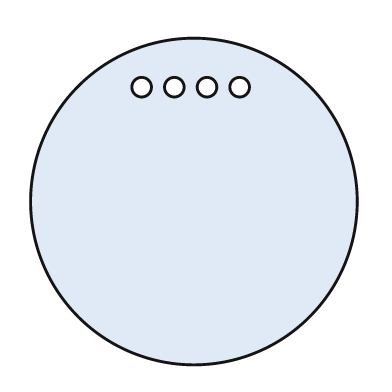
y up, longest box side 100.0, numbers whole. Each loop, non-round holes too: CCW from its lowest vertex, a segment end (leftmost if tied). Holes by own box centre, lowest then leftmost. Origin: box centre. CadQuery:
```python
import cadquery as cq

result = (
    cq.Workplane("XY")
    .moveTo(0.0, 0.0)
    .circle(50.0)
    .moveTo(-16.0, 35.0)
    .circle(3.0)
    .moveTo(-6.0, 35.0)
    .circle(3.0)
    .moveTo(4.0, 35.0)
    .circle(3.0)
    .moveTo(14.0, 35.0)
    .circle(3.0)
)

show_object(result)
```